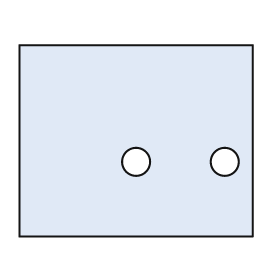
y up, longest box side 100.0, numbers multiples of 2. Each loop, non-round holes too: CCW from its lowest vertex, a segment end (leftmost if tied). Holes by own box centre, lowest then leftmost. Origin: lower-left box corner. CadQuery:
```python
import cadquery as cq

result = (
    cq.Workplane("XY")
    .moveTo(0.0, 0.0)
    .lineTo(100.0, 0.0)
    .lineTo(100.0, 82.0)
    .lineTo(0.0, 82.0)
    .close()
    .moveTo(50.0, 32.0)
    .circle(6.0)
    .moveTo(88.0, 32.0)
    .circle(6.0)
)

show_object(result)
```